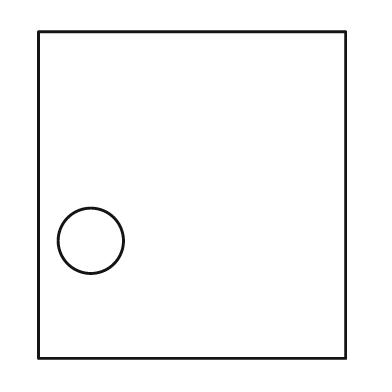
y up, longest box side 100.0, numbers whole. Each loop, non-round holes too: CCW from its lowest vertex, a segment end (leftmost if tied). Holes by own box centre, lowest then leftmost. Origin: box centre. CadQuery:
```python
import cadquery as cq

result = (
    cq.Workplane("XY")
    .moveTo(-47.0, -50.0)
    .lineTo(47.0, -50.0)
    .lineTo(47.0, 50.0)
    .lineTo(-47.0, 50.0)
    .close()
    .moveTo(-31.0, -14.0)
    .circle(10.0)
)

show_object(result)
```